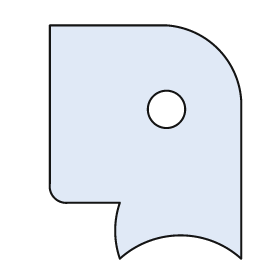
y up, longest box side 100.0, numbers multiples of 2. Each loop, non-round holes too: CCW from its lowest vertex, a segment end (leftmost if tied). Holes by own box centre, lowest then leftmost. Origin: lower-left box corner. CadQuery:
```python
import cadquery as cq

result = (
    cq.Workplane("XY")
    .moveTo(30.0, 0.0)
    .threePointArc((56.0, 10.0), (82.0, 0.0))
    .lineTo(82.0, 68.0)
    .threePointArc((72.0, 90.0), (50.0, 100.0))
    .lineTo(0.0, 100.0)
    .lineTo(0.0, 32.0)
    .threePointArc((2.0, 26.0), (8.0, 24.0))
    .lineTo(30.0, 24.0)
    .threePointArc((28.0, 12.0), (30.0, 0.0))
    .close()
    .moveTo(50.0, 64.0)
    .circle(8.0)
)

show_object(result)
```